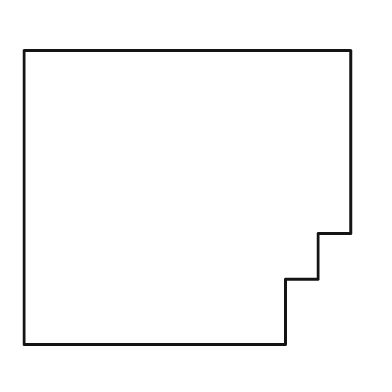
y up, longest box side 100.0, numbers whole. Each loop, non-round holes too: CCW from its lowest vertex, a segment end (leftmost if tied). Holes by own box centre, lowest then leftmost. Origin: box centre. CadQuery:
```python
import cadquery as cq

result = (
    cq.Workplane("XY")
    .moveTo(-50.0, -45.0)
    .lineTo(30.0, -45.0)
    .lineTo(30.0, -25.0)
    .lineTo(40.0, -25.0)
    .lineTo(40.0, -11.0)
    .lineTo(50.0, -11.0)
    .lineTo(50.0, 45.0)
    .lineTo(-50.0, 45.0)
    .close()
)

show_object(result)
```